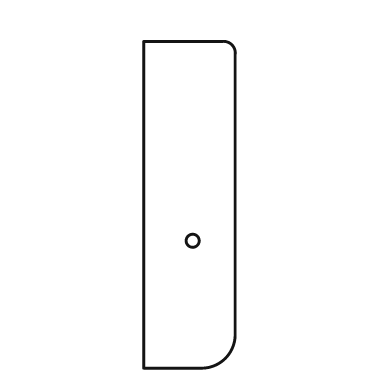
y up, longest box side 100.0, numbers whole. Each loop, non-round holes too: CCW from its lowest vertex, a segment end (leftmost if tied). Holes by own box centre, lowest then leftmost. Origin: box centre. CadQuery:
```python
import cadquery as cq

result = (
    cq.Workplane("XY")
    .moveTo(-14.0, -50.0)
    .lineTo(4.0, -50.0)
    .threePointArc((11.0, -47.0), (14.0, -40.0))
    .lineTo(14.0, 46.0)
    .threePointArc((13.0, 49.0), (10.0, 50.0))
    .lineTo(-14.0, 50.0)
    .close()
    .moveTo(1.0, -11.0)
    .circle(2.0)
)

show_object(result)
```